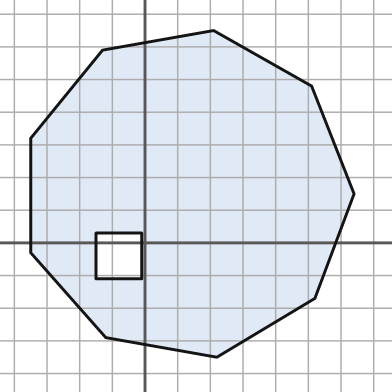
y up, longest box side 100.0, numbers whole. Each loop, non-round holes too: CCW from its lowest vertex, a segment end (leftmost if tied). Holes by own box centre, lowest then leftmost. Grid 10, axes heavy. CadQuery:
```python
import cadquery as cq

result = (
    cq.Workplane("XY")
    .moveTo(22.0, -35.0)
    .lineTo(52.0, -17.0)
    .lineTo(64.0, 15.0)
    .lineTo(51.0, 48.0)
    .lineTo(21.0, 65.0)
    .lineTo(-13.0, 59.0)
    .lineTo(-35.0, 32.0)
    .lineTo(-35.0, -3.0)
    .lineTo(-12.0, -29.0)
    .close()
    .moveTo(-15.0, -11.0)
    .lineTo(-1.0, -11.0)
    .lineTo(-1.0, 3.0)
    .lineTo(-15.0, 3.0)
    .close()
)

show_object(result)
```